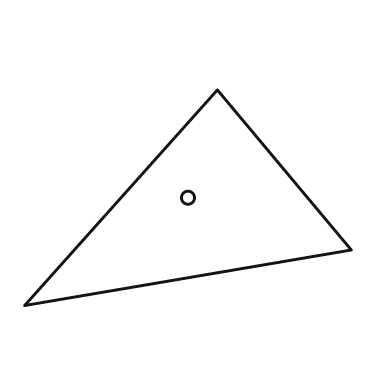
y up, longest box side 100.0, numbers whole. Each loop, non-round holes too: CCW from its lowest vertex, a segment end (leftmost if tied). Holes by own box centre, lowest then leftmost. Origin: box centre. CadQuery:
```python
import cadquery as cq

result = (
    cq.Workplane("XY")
    .moveTo(-50.0, -33.0)
    .lineTo(50.0, -16.0)
    .lineTo(9.0, 33.0)
    .close()
    .moveTo(0.0, 0.0)
    .circle(2.0)
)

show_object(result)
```